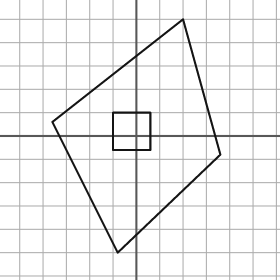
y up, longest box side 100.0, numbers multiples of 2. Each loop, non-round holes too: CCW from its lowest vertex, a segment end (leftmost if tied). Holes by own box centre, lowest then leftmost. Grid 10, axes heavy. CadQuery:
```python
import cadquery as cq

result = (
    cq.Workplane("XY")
    .moveTo(-8.0, -50.0)
    .lineTo(36.0, -8.0)
    .lineTo(20.0, 50.0)
    .lineTo(-36.0, 6.0)
    .close()
    .moveTo(-10.0, -6.0)
    .lineTo(6.0, -6.0)
    .lineTo(6.0, 10.0)
    .lineTo(-10.0, 10.0)
    .close()
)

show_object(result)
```